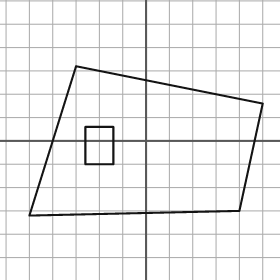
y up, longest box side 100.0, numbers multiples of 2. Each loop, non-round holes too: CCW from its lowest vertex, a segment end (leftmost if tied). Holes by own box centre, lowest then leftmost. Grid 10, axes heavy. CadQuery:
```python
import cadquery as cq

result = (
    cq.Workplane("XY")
    .moveTo(-50.0, -32.0)
    .lineTo(40.0, -30.0)
    .lineTo(50.0, 16.0)
    .lineTo(-30.0, 32.0)
    .close()
    .moveTo(-26.0, -10.0)
    .lineTo(-14.0, -10.0)
    .lineTo(-14.0, 6.0)
    .lineTo(-26.0, 6.0)
    .close()
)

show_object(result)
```